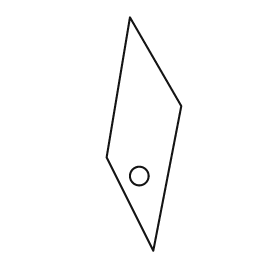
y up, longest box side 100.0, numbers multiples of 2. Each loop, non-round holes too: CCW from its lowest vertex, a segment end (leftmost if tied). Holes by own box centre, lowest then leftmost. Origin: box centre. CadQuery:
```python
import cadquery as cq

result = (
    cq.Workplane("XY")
    .moveTo(4.0, -50.0)
    .lineTo(16.0, 12.0)
    .lineTo(-6.0, 50.0)
    .lineTo(-16.0, -10.0)
    .close()
    .moveTo(-2.0, -18.0)
    .circle(4.0)
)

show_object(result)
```